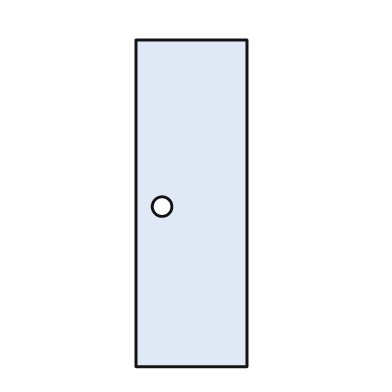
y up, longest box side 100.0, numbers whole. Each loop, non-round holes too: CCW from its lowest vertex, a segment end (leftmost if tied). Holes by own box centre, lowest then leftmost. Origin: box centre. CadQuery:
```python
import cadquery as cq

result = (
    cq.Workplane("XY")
    .moveTo(-17.0, -50.0)
    .lineTo(17.0, -50.0)
    .lineTo(17.0, 50.0)
    .lineTo(-17.0, 50.0)
    .close()
    .moveTo(-9.0, -1.0)
    .circle(3.0)
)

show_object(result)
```